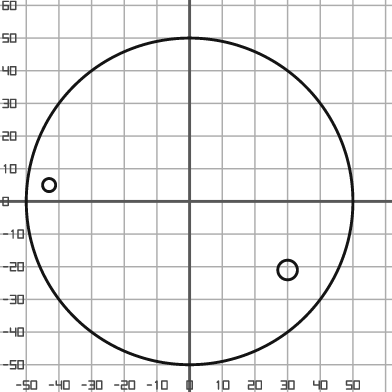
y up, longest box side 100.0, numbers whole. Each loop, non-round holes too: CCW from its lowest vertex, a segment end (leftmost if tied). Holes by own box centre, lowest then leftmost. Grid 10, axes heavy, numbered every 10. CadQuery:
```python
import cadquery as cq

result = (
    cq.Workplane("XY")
    .moveTo(0.0, 0.0)
    .circle(50.0)
    .moveTo(30.0, -21.0)
    .circle(3.0)
    .moveTo(-43.0, 5.0)
    .circle(2.0)
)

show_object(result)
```